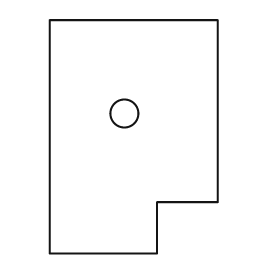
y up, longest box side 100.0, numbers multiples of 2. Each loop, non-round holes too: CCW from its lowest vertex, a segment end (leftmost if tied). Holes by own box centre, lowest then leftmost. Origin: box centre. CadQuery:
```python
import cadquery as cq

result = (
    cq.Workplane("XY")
    .moveTo(-36.0, -50.0)
    .lineTo(10.0, -50.0)
    .lineTo(10.0, -28.0)
    .lineTo(36.0, -28.0)
    .lineTo(36.0, 50.0)
    .lineTo(-36.0, 50.0)
    .close()
    .moveTo(-4.0, 10.0)
    .circle(6.0)
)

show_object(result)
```